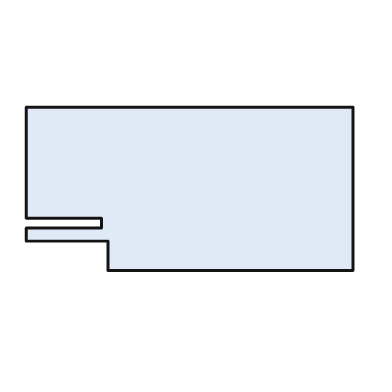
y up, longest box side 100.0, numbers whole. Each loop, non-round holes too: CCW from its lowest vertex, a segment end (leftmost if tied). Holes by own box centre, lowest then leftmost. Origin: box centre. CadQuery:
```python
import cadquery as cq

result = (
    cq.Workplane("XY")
    .moveTo(-25.0, -25.0)
    .lineTo(50.0, -25.0)
    .lineTo(50.0, 25.0)
    .lineTo(-50.0, 25.0)
    .lineTo(-50.0, -9.0)
    .lineTo(-27.0, -9.0)
    .lineTo(-27.0, -12.0)
    .lineTo(-50.0, -12.0)
    .lineTo(-50.0, -16.0)
    .lineTo(-25.0, -16.0)
    .close()
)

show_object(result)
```